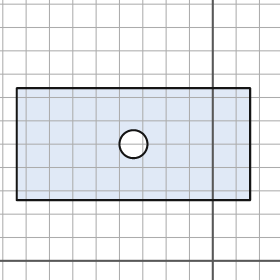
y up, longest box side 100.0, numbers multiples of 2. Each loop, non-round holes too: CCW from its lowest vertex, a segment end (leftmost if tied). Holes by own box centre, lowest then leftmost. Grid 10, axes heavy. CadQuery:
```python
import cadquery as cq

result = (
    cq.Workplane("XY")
    .moveTo(-84.0, 26.0)
    .lineTo(16.0, 26.0)
    .lineTo(16.0, 74.0)
    .lineTo(-84.0, 74.0)
    .close()
    .moveTo(-34.0, 50.0)
    .circle(6.0)
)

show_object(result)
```